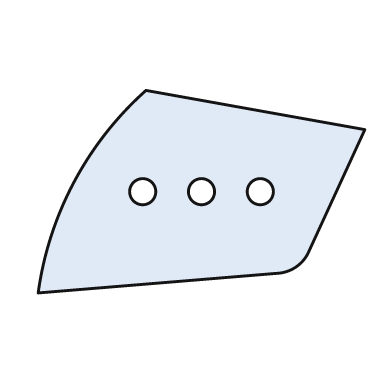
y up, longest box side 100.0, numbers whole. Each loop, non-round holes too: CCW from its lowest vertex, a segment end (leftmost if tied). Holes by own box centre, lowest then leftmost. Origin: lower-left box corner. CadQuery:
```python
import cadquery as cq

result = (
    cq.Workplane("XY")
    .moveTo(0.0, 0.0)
    .lineTo(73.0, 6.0)
    .threePointArc((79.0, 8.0), (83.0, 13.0))
    .lineTo(100.0, 50.0)
    .lineTo(33.0, 62.0)
    .threePointArc((11.0, 34.0), (0.0, 0.0))
    .close()
    .moveTo(32.0, 31.0)
    .circle(4.0)
    .moveTo(50.0, 31.0)
    .circle(4.0)
    .moveTo(68.0, 31.0)
    .circle(4.0)
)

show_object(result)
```